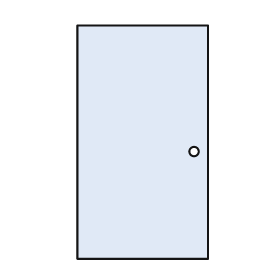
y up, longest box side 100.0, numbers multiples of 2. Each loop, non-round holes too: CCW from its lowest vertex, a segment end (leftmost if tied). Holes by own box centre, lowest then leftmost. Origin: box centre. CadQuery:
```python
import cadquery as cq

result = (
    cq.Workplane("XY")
    .moveTo(-28.0, -50.0)
    .lineTo(28.0, -50.0)
    .lineTo(28.0, 50.0)
    .lineTo(-28.0, 50.0)
    .close()
    .moveTo(22.0, -4.0)
    .circle(2.0)
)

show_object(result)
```